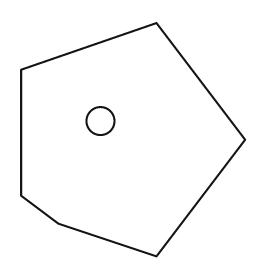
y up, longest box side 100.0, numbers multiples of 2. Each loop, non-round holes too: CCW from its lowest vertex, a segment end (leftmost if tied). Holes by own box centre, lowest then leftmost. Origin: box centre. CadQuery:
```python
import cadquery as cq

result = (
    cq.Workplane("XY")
    .moveTo(10.0, -50.0)
    .lineTo(48.0, 0.0)
    .lineTo(10.0, 50.0)
    .lineTo(-48.0, 30.0)
    .lineTo(-48.0, -24.0)
    .lineTo(-32.0, -36.0)
    .close()
    .moveTo(-14.0, 8.0)
    .circle(6.0)
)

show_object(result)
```